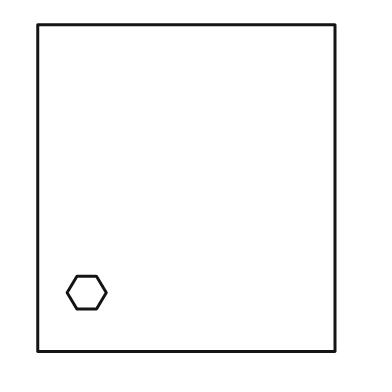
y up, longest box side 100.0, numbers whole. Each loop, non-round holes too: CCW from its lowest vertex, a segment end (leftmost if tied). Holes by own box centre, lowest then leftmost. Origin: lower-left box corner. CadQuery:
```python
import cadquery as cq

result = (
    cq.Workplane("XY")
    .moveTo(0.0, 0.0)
    .lineTo(91.0, 0.0)
    .lineTo(91.0, 100.0)
    .lineTo(0.0, 100.0)
    .close()
    .moveTo(12.0, 13.0)
    .lineTo(18.0, 13.0)
    .lineTo(21.0, 18.0)
    .lineTo(18.0, 23.0)
    .lineTo(12.0, 23.0)
    .lineTo(9.0, 18.0)
    .close()
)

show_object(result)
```